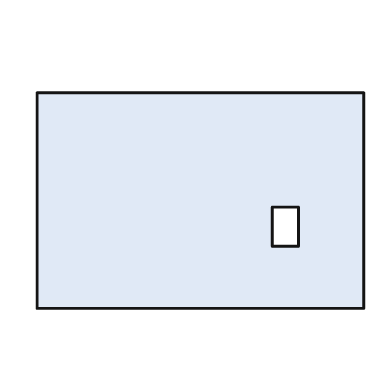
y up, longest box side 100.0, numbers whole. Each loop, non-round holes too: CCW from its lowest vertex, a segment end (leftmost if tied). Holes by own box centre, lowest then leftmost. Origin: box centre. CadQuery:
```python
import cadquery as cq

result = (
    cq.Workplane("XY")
    .moveTo(-50.0, -33.0)
    .lineTo(50.0, -33.0)
    .lineTo(50.0, 33.0)
    .lineTo(-50.0, 33.0)
    .close()
    .moveTo(22.0, -14.0)
    .lineTo(30.0, -14.0)
    .lineTo(30.0, -2.0)
    .lineTo(22.0, -2.0)
    .close()
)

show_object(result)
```